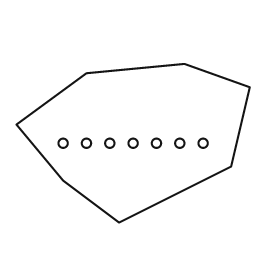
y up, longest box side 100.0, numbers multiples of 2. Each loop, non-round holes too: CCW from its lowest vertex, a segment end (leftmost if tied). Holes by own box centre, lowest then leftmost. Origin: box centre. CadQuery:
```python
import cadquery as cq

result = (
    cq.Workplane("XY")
    .moveTo(-6.0, -34.0)
    .lineTo(42.0, -10.0)
    .lineTo(50.0, 24.0)
    .lineTo(22.0, 34.0)
    .lineTo(-20.0, 30.0)
    .lineTo(-50.0, 8.0)
    .lineTo(-30.0, -16.0)
    .close()
    .moveTo(-30.0, 0.0)
    .circle(2.0)
    .moveTo(-20.0, 0.0)
    .circle(2.0)
    .moveTo(-10.0, 0.0)
    .circle(2.0)
    .moveTo(0.0, 0.0)
    .circle(2.0)
    .moveTo(10.0, 0.0)
    .circle(2.0)
    .moveTo(20.0, 0.0)
    .circle(2.0)
    .moveTo(30.0, 0.0)
    .circle(2.0)
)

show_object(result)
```